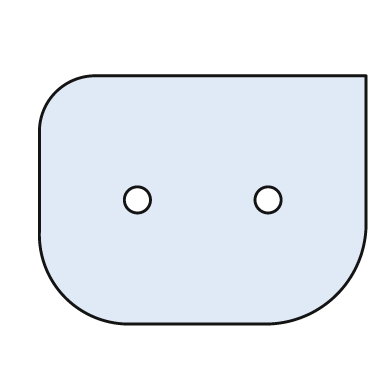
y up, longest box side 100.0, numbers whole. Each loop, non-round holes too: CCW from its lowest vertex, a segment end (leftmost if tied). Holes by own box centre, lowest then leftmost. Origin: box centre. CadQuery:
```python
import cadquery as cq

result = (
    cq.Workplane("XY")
    .moveTo(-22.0, -38.0)
    .lineTo(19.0, -38.0)
    .threePointArc((41.0, -29.0), (50.0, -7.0))
    .lineTo(50.0, 38.0)
    .lineTo(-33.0, 38.0)
    .threePointArc((-45.0, 33.0), (-50.0, 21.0))
    .lineTo(-50.0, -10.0)
    .threePointArc((-42.0, -30.0), (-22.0, -38.0))
    .close()
    .moveTo(-20.0, 0.0)
    .circle(4.0)
    .moveTo(20.0, 0.0)
    .circle(4.0)
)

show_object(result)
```